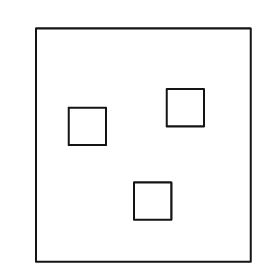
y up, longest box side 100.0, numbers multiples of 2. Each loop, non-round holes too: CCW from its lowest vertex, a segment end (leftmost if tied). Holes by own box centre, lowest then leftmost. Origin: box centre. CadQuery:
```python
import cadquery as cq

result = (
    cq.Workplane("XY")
    .moveTo(-46.0, -50.0)
    .lineTo(46.0, -50.0)
    .lineTo(46.0, 50.0)
    .lineTo(-46.0, 50.0)
    .close()
    .moveTo(-4.0, -32.0)
    .lineTo(12.0, -32.0)
    .lineTo(12.0, -16.0)
    .lineTo(-4.0, -16.0)
    .close()
    .moveTo(-32.0, 0.0)
    .lineTo(-16.0, 0.0)
    .lineTo(-16.0, 16.0)
    .lineTo(-32.0, 16.0)
    .close()
    .moveTo(10.0, 8.0)
    .lineTo(26.0, 8.0)
    .lineTo(26.0, 24.0)
    .lineTo(10.0, 24.0)
    .close()
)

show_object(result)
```